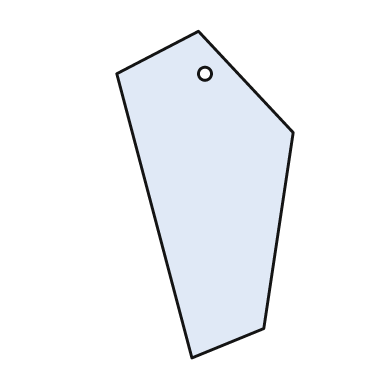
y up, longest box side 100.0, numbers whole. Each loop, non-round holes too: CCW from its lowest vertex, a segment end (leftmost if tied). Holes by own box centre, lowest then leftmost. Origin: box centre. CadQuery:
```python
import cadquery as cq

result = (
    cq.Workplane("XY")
    .moveTo(-4.0, -50.0)
    .lineTo(18.0, -41.0)
    .lineTo(27.0, 19.0)
    .lineTo(-2.0, 50.0)
    .lineTo(-27.0, 37.0)
    .close()
    .moveTo(0.0, 37.0)
    .circle(2.0)
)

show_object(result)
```